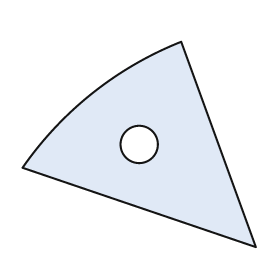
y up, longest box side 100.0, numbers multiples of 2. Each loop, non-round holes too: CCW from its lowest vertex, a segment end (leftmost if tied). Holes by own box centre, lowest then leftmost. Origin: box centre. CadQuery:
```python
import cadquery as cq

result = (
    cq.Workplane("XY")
    .moveTo(50.0, -44.0)
    .lineTo(18.0, 44.0)
    .threePointArc((-20.0, 22.0), (-50.0, -10.0))
    .close()
    .moveTo(0.0, 0.0)
    .circle(8.0)
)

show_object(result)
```